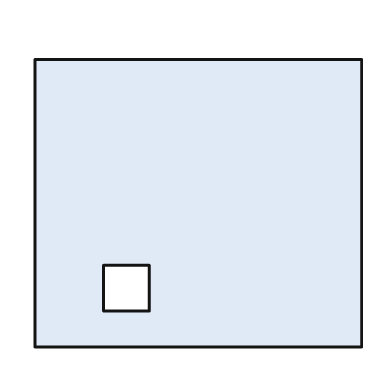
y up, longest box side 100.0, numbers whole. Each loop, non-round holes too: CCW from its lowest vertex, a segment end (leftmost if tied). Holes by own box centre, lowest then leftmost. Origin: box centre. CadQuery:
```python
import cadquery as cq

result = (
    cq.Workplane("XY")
    .moveTo(-50.0, -44.0)
    .lineTo(50.0, -44.0)
    .lineTo(50.0, 44.0)
    .lineTo(-50.0, 44.0)
    .close()
    .moveTo(-29.0, -33.0)
    .lineTo(-15.0, -33.0)
    .lineTo(-15.0, -19.0)
    .lineTo(-29.0, -19.0)
    .close()
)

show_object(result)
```